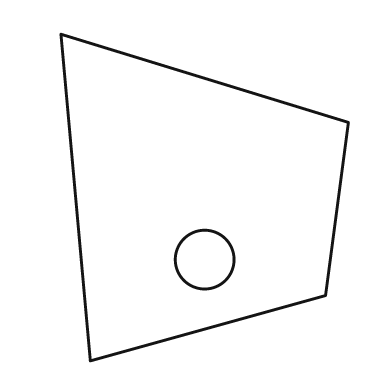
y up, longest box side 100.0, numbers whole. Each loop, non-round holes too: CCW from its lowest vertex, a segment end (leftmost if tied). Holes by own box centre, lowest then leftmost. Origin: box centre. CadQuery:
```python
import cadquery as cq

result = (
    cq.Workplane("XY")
    .moveTo(-35.0, -50.0)
    .lineTo(37.0, -30.0)
    .lineTo(44.0, 23.0)
    .lineTo(-44.0, 50.0)
    .close()
    .moveTo(0.0, -19.0)
    .circle(9.0)
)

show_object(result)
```